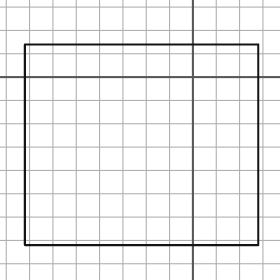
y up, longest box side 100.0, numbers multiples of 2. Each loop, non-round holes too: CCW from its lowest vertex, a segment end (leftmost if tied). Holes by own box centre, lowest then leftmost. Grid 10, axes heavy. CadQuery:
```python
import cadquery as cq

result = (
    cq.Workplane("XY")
    .moveTo(-72.0, -72.0)
    .lineTo(28.0, -72.0)
    .lineTo(28.0, 14.0)
    .lineTo(-72.0, 14.0)
    .close()
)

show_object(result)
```